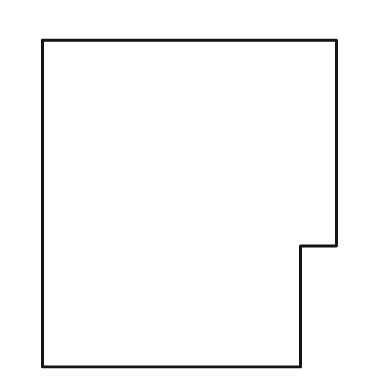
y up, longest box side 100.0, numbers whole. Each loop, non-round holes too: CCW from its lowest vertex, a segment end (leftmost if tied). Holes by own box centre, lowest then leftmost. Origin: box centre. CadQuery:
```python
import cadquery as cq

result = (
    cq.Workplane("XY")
    .moveTo(-45.0, -50.0)
    .lineTo(34.0, -50.0)
    .lineTo(34.0, -13.0)
    .lineTo(45.0, -13.0)
    .lineTo(45.0, 50.0)
    .lineTo(-45.0, 50.0)
    .close()
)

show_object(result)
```